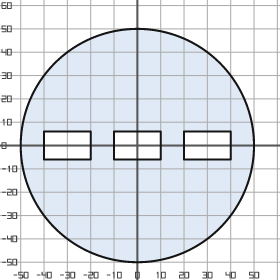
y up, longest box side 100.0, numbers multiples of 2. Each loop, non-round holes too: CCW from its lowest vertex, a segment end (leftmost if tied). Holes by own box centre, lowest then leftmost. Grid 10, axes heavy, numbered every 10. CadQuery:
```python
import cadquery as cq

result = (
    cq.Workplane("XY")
    .moveTo(0.0, 0.0)
    .circle(50.0)
    .moveTo(-40.0, -6.0)
    .lineTo(-20.0, -6.0)
    .lineTo(-20.0, 6.0)
    .lineTo(-40.0, 6.0)
    .close()
    .moveTo(-10.0, -6.0)
    .lineTo(10.0, -6.0)
    .lineTo(10.0, 6.0)
    .lineTo(-10.0, 6.0)
    .close()
    .moveTo(20.0, -6.0)
    .lineTo(40.0, -6.0)
    .lineTo(40.0, 6.0)
    .lineTo(20.0, 6.0)
    .close()
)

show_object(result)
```